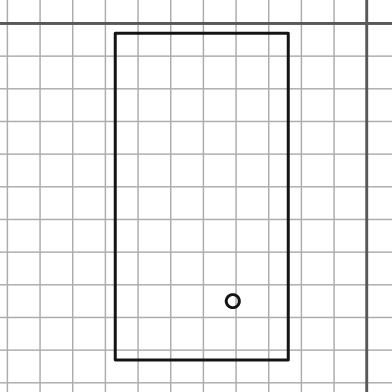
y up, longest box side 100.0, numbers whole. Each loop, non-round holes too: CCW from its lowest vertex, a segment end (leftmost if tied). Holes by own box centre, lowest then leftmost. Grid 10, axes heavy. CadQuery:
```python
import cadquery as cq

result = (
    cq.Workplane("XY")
    .moveTo(-77.0, -103.0)
    .lineTo(-24.0, -103.0)
    .lineTo(-24.0, -3.0)
    .lineTo(-77.0, -3.0)
    .close()
    .moveTo(-41.0, -85.0)
    .circle(2.0)
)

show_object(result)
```